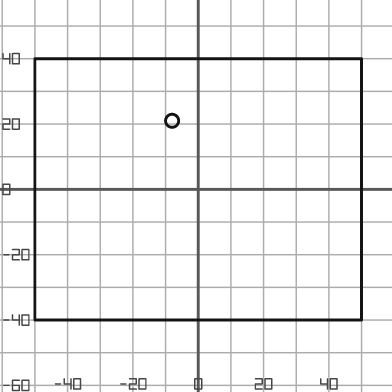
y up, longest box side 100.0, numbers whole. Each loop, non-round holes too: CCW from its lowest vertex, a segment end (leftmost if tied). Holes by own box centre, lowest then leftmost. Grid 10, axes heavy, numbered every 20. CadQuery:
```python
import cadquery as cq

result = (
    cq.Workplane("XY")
    .moveTo(-50.0, -40.0)
    .lineTo(50.0, -40.0)
    .lineTo(50.0, 40.0)
    .lineTo(-50.0, 40.0)
    .close()
    .moveTo(-8.0, 21.0)
    .circle(2.0)
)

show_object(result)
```